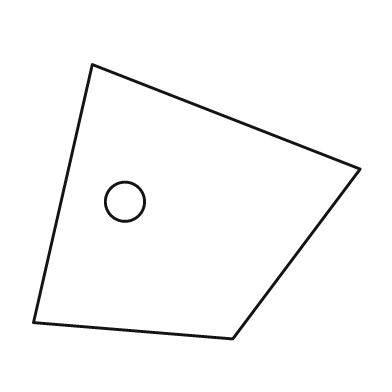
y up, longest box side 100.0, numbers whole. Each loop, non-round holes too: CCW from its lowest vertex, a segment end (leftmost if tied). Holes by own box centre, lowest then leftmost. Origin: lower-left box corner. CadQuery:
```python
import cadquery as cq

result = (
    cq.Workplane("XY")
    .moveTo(61.0, 0.0)
    .lineTo(100.0, 52.0)
    .lineTo(18.0, 84.0)
    .lineTo(0.0, 5.0)
    .close()
    .moveTo(28.0, 42.0)
    .circle(6.0)
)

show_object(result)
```